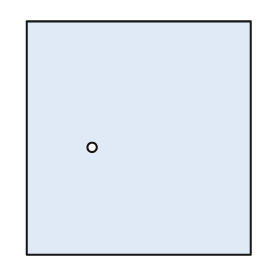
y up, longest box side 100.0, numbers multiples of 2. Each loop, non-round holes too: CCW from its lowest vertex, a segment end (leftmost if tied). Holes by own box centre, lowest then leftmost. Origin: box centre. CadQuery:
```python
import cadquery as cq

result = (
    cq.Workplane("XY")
    .moveTo(-48.0, -50.0)
    .lineTo(48.0, -50.0)
    .lineTo(48.0, 50.0)
    .lineTo(-48.0, 50.0)
    .close()
    .moveTo(-20.0, -4.0)
    .circle(2.0)
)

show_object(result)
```